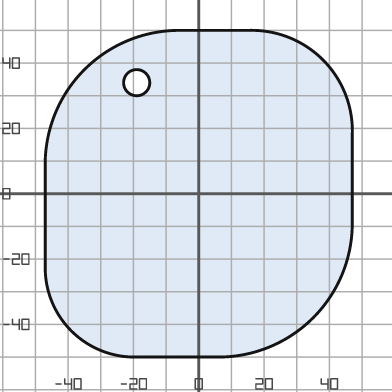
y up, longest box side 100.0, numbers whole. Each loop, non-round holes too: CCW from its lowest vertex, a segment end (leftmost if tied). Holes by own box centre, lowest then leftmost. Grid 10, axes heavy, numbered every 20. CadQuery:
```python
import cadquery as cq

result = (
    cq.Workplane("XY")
    .moveTo(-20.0, -50.0)
    .lineTo(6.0, -50.0)
    .threePointArc((35.0, -38.0), (47.0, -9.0))
    .lineTo(47.0, 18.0)
    .threePointArc((38.0, 41.0), (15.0, 50.0))
    .lineTo(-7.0, 50.0)
    .threePointArc((-35.0, 38.0), (-47.0, 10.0))
    .lineTo(-47.0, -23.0)
    .threePointArc((-39.0, -42.0), (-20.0, -50.0))
    .close()
    .moveTo(-19.0, 34.0)
    .circle(4.0)
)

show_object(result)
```